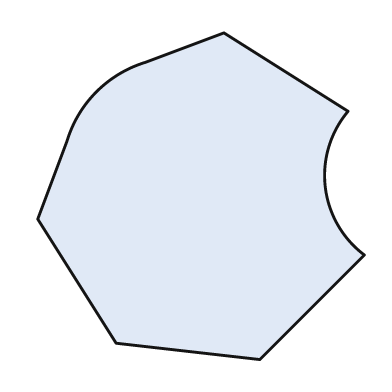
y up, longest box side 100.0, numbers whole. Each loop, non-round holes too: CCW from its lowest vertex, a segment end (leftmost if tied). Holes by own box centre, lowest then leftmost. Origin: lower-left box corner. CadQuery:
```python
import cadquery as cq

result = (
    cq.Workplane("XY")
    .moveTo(68.0, 0.0)
    .lineTo(100.0, 32.0)
    .threePointArc((88.0, 53.0), (95.0, 76.0))
    .lineTo(57.0, 100.0)
    .lineTo(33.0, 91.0)
    .threePointArc((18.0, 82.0), (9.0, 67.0))
    .lineTo(0.0, 43.0)
    .lineTo(24.0, 5.0)
    .close()
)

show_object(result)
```